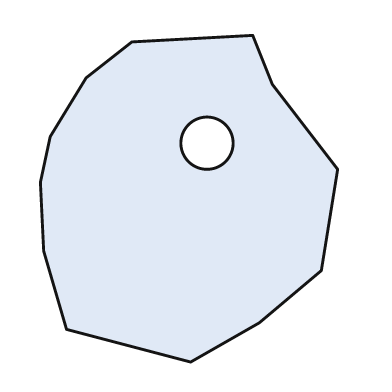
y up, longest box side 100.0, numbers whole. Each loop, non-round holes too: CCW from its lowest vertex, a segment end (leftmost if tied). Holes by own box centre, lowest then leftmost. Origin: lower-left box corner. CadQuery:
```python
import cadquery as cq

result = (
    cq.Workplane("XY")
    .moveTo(46.0, 0.0)
    .lineTo(67.0, 12.0)
    .lineTo(86.0, 28.0)
    .lineTo(91.0, 59.0)
    .lineTo(71.0, 85.0)
    .lineTo(65.0, 100.0)
    .lineTo(28.0, 98.0)
    .lineTo(14.0, 87.0)
    .lineTo(3.0, 69.0)
    .lineTo(0.0, 55.0)
    .lineTo(1.0, 34.0)
    .lineTo(8.0, 10.0)
    .close()
    .moveTo(51.0, 67.0)
    .circle(8.0)
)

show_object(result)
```